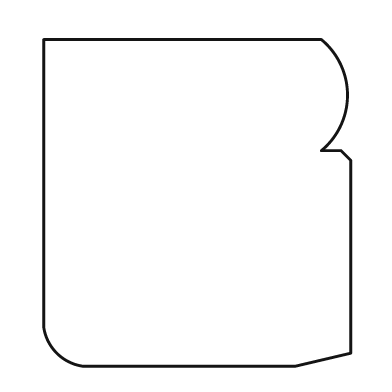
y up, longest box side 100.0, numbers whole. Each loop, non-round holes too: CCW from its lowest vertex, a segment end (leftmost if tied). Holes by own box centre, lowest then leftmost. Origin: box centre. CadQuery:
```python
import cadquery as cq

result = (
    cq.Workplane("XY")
    .moveTo(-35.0, -50.0)
    .lineTo(30.0, -50.0)
    .lineTo(47.0, -46.0)
    .lineTo(47.0, 13.0)
    .lineTo(44.0, 16.0)
    .lineTo(38.0, 16.0)
    .threePointArc((46.0, 33.0), (38.0, 50.0))
    .lineTo(-47.0, 50.0)
    .lineTo(-47.0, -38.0)
    .threePointArc((-43.0, -46.0), (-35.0, -50.0))
    .close()
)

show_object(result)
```